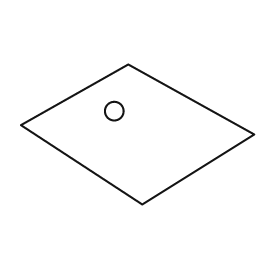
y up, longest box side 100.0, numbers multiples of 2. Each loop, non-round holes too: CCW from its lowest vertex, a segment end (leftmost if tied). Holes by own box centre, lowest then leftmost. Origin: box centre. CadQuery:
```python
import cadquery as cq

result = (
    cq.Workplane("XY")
    .moveTo(2.0, -30.0)
    .lineTo(50.0, 0.0)
    .lineTo(-4.0, 30.0)
    .lineTo(-50.0, 4.0)
    .close()
    .moveTo(-10.0, 10.0)
    .circle(4.0)
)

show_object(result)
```